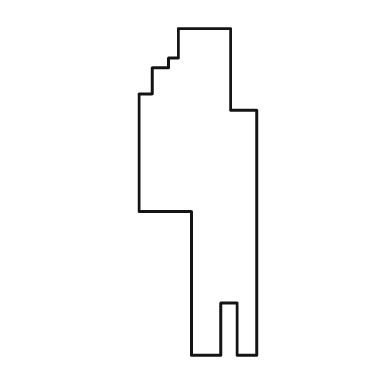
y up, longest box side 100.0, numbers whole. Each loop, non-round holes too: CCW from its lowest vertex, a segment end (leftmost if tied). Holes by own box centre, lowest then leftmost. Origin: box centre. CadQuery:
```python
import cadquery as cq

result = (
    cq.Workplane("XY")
    .moveTo(-2.0, -50.0)
    .lineTo(7.0, -50.0)
    .lineTo(7.0, -34.0)
    .lineTo(12.0, -34.0)
    .lineTo(12.0, -50.0)
    .lineTo(18.0, -50.0)
    .lineTo(18.0, 25.0)
    .lineTo(10.0, 25.0)
    .lineTo(10.0, 50.0)
    .lineTo(-6.0, 50.0)
    .lineTo(-6.0, 41.0)
    .lineTo(-9.0, 41.0)
    .lineTo(-9.0, 38.0)
    .lineTo(-14.0, 38.0)
    .lineTo(-14.0, 30.0)
    .lineTo(-18.0, 30.0)
    .lineTo(-18.0, -6.0)
    .lineTo(-2.0, -6.0)
    .close()
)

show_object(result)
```